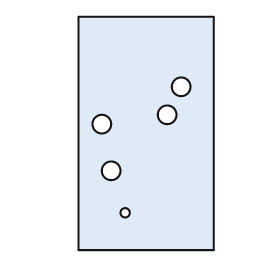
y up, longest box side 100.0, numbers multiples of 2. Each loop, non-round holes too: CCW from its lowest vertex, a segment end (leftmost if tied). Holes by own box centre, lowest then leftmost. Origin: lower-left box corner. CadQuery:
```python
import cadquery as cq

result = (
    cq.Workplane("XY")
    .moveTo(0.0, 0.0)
    .lineTo(58.0, 0.0)
    .lineTo(58.0, 100.0)
    .lineTo(0.0, 100.0)
    .close()
    .moveTo(20.0, 16.0)
    .circle(2.0)
    .moveTo(14.0, 34.0)
    .circle(4.0)
    .moveTo(10.0, 54.0)
    .circle(4.0)
    .moveTo(38.0, 58.0)
    .circle(4.0)
    .moveTo(44.0, 70.0)
    .circle(4.0)
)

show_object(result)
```